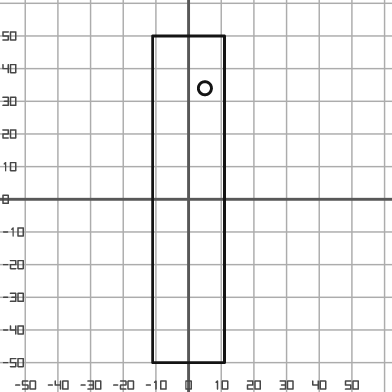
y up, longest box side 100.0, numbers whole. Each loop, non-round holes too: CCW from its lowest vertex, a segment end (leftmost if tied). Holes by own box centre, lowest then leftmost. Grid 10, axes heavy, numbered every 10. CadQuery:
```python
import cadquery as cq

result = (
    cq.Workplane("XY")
    .moveTo(-11.0, -50.0)
    .lineTo(11.0, -50.0)
    .lineTo(11.0, 50.0)
    .lineTo(-11.0, 50.0)
    .close()
    .moveTo(5.0, 34.0)
    .circle(2.0)
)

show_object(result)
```